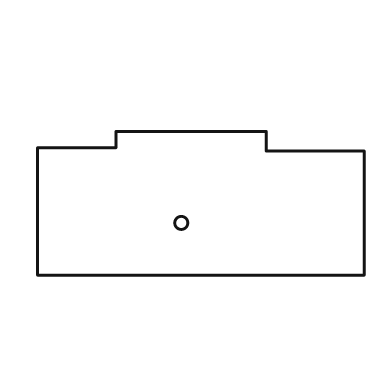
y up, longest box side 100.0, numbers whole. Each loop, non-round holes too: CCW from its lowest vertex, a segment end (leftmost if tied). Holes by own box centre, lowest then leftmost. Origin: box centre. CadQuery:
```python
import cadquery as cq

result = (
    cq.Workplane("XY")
    .moveTo(-50.0, -22.0)
    .lineTo(50.0, -22.0)
    .lineTo(50.0, 16.0)
    .lineTo(20.0, 16.0)
    .lineTo(20.0, 22.0)
    .lineTo(-26.0, 22.0)
    .lineTo(-26.0, 17.0)
    .lineTo(-50.0, 17.0)
    .close()
    .moveTo(-6.0, -6.0)
    .circle(2.0)
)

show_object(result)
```